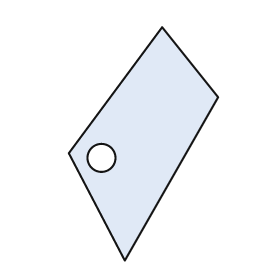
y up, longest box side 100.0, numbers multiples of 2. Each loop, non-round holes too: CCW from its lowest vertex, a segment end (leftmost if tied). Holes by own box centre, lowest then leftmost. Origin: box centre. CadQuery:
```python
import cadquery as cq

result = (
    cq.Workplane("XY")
    .moveTo(-8.0, -50.0)
    .lineTo(32.0, 20.0)
    .lineTo(8.0, 50.0)
    .lineTo(-32.0, -4.0)
    .close()
    .moveTo(-18.0, -6.0)
    .circle(6.0)
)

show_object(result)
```